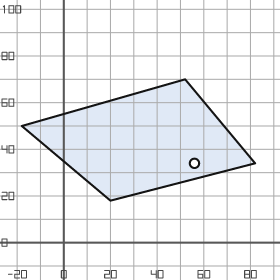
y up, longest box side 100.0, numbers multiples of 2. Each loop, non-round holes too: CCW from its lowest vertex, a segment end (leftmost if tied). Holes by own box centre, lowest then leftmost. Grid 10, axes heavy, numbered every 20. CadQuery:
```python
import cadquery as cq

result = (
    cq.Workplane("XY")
    .moveTo(20.0, 18.0)
    .lineTo(82.0, 34.0)
    .lineTo(52.0, 70.0)
    .lineTo(-18.0, 50.0)
    .close()
    .moveTo(56.0, 34.0)
    .circle(2.0)
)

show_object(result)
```